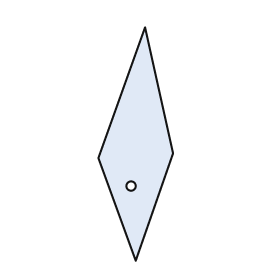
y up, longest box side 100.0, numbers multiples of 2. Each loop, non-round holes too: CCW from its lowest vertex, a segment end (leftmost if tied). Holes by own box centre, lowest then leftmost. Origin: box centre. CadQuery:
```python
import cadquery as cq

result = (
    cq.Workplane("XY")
    .moveTo(0.0, -50.0)
    .lineTo(16.0, -4.0)
    .lineTo(4.0, 50.0)
    .lineTo(-16.0, -6.0)
    .close()
    .moveTo(-2.0, -18.0)
    .circle(2.0)
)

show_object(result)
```